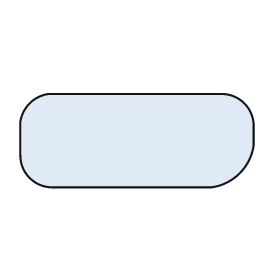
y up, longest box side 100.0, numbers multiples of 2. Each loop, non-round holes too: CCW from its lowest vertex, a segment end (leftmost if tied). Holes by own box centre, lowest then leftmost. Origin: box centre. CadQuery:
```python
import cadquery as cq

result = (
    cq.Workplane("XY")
    .moveTo(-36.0, -20.0)
    .lineTo(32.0, -20.0)
    .threePointArc((44.0, -14.0), (50.0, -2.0))
    .lineTo(50.0, 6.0)
    .threePointArc((46.0, 16.0), (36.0, 20.0))
    .lineTo(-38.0, 20.0)
    .threePointArc((-46.0, 16.0), (-50.0, 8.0))
    .lineTo(-50.0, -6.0)
    .threePointArc((-46.0, -16.0), (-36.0, -20.0))
    .close()
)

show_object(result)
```